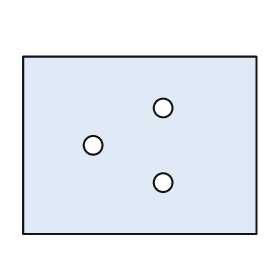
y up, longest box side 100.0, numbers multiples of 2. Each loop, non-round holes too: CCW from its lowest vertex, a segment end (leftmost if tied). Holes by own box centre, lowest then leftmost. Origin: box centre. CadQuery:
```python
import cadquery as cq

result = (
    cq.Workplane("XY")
    .moveTo(-50.0, -38.0)
    .lineTo(50.0, -38.0)
    .lineTo(50.0, 38.0)
    .lineTo(-50.0, 38.0)
    .close()
    .moveTo(10.0, -16.0)
    .circle(4.0)
    .moveTo(-20.0, 0.0)
    .circle(4.0)
    .moveTo(10.0, 16.0)
    .circle(4.0)
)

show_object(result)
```